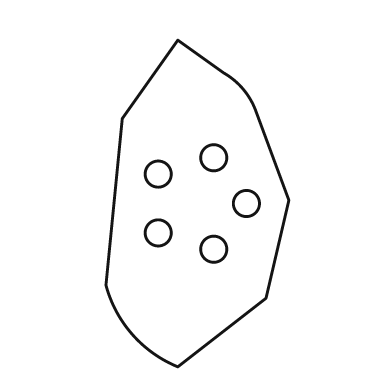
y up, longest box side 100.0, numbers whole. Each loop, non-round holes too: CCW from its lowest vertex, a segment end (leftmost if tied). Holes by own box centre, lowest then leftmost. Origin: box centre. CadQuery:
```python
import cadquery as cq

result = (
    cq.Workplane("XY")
    .moveTo(-6.0, -50.0)
    .lineTo(21.0, -29.0)
    .lineTo(28.0, 1.0)
    .lineTo(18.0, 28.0)
    .threePointArc((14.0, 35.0), (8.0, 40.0))
    .lineTo(-6.0, 50.0)
    .lineTo(-23.0, 26.0)
    .lineTo(-28.0, -25.0)
    .threePointArc((-20.0, -40.0), (-6.0, -50.0))
    .close()
    .moveTo(5.0, -14.0)
    .circle(4.0)
    .moveTo(-12.0, -9.0)
    .circle(4.0)
    .moveTo(15.0, 0.0)
    .circle(4.0)
    .moveTo(-12.0, 9.0)
    .circle(4.0)
    .moveTo(5.0, 14.0)
    .circle(4.0)
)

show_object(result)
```